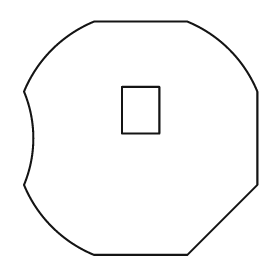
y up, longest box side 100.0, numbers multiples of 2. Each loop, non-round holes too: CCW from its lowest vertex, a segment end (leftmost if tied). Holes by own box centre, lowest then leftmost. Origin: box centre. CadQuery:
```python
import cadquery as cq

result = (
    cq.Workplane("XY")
    .moveTo(-20.0, -50.0)
    .lineTo(20.0, -50.0)
    .lineTo(50.0, -20.0)
    .lineTo(50.0, 20.0)
    .threePointArc((38.0, 38.0), (20.0, 50.0))
    .lineTo(-20.0, 50.0)
    .threePointArc((-38.0, 38.0), (-50.0, 20.0))
    .threePointArc((-46.0, 0.0), (-50.0, -20.0))
    .threePointArc((-38.0, -38.0), (-20.0, -50.0))
    .close()
    .moveTo(-8.0, 2.0)
    .lineTo(8.0, 2.0)
    .lineTo(8.0, 22.0)
    .lineTo(-8.0, 22.0)
    .close()
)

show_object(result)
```